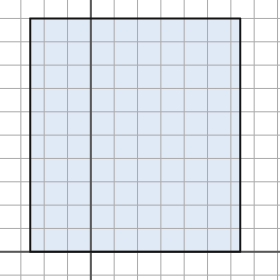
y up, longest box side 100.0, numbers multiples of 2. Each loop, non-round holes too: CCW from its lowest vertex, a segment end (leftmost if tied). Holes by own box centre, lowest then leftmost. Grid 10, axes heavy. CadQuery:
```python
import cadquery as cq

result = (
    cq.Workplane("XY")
    .moveTo(-26.0, 0.0)
    .lineTo(64.0, 0.0)
    .lineTo(64.0, 100.0)
    .lineTo(-26.0, 100.0)
    .close()
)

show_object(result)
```